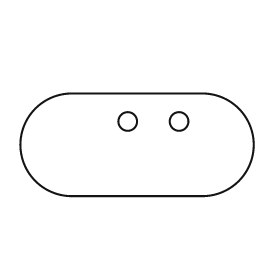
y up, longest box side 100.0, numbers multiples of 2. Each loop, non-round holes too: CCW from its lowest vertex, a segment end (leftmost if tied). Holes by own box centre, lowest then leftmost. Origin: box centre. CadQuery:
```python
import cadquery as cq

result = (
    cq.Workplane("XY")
    .moveTo(-28.0, -22.0)
    .lineTo(28.0, -22.0)
    .threePointArc((50.0, 0.0), (28.0, 22.0))
    .lineTo(-28.0, 22.0)
    .threePointArc((-50.0, 0.0), (-28.0, -22.0))
    .close()
    .moveTo(-4.0, 10.0)
    .circle(4.0)
    .moveTo(18.0, 10.0)
    .circle(4.0)
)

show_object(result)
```